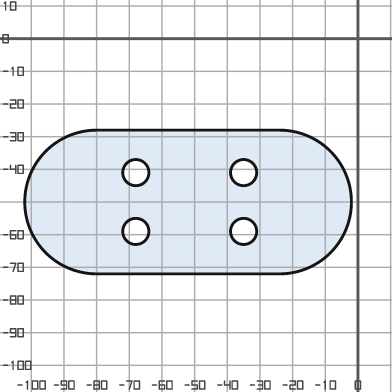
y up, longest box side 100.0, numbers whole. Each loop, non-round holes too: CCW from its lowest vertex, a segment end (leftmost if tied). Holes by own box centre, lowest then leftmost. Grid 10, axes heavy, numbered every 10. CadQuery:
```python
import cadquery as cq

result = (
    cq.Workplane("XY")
    .moveTo(-80.0, -72.0)
    .lineTo(-24.0, -72.0)
    .threePointArc((-2.0, -50.0), (-24.0, -28.0))
    .lineTo(-80.0, -28.0)
    .threePointArc((-102.0, -50.0), (-80.0, -72.0))
    .close()
    .moveTo(-68.0, -59.0)
    .circle(4.0)
    .moveTo(-35.0, -59.0)
    .circle(4.0)
    .moveTo(-68.0, -41.0)
    .circle(4.0)
    .moveTo(-35.0, -41.0)
    .circle(4.0)
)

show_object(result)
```